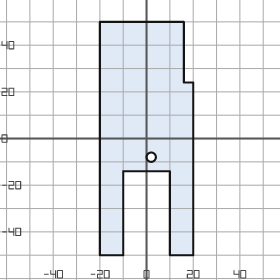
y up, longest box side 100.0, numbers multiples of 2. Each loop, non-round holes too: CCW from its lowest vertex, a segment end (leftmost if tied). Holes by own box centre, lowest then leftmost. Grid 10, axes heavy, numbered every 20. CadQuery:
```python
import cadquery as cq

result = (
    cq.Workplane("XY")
    .moveTo(-20.0, -50.0)
    .lineTo(-10.0, -50.0)
    .lineTo(-10.0, -14.0)
    .lineTo(10.0, -14.0)
    .lineTo(10.0, -50.0)
    .lineTo(20.0, -50.0)
    .lineTo(20.0, 24.0)
    .lineTo(16.0, 24.0)
    .lineTo(16.0, 50.0)
    .lineTo(-20.0, 50.0)
    .close()
    .moveTo(2.0, -8.0)
    .circle(2.0)
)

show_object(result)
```